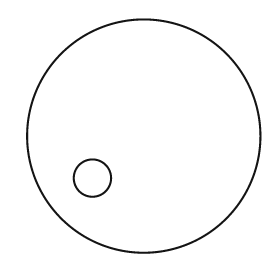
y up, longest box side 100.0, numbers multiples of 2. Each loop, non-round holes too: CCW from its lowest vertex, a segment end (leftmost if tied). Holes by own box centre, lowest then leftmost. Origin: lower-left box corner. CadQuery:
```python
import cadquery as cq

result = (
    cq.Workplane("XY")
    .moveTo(50.0, 50.0)
    .circle(50.0)
    .moveTo(28.0, 32.0)
    .circle(8.0)
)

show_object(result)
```